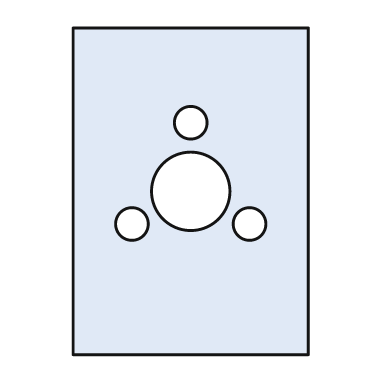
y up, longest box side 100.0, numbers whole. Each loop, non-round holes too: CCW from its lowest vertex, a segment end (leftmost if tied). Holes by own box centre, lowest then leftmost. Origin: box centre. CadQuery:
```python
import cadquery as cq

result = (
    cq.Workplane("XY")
    .moveTo(-36.0, -50.0)
    .lineTo(36.0, -50.0)
    .lineTo(36.0, 50.0)
    .lineTo(-36.0, 50.0)
    .close()
    .moveTo(-18.0, -10.0)
    .circle(5.0)
    .moveTo(18.0, -10.0)
    .circle(5.0)
    .moveTo(0.0, 0.0)
    .circle(12.0)
    .moveTo(0.0, 21.0)
    .circle(5.0)
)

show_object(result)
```